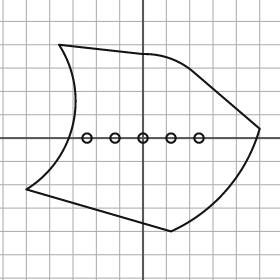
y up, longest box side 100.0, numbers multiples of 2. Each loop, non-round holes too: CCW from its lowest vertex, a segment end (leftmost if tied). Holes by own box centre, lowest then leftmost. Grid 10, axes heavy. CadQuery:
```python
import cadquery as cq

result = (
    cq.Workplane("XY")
    .moveTo(12.0, -40.0)
    .threePointArc((36.0, -22.0), (50.0, 4.0))
    .lineTo(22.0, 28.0)
    .threePointArc((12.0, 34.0), (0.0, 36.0))
    .lineTo(-36.0, 40.0)
    .threePointArc((-30.0, 6.0), (-50.0, -22.0))
    .close()
    .moveTo(-24.0, 0.0)
    .circle(2.0)
    .moveTo(-12.0, 0.0)
    .circle(2.0)
    .moveTo(0.0, 0.0)
    .circle(2.0)
    .moveTo(12.0, 0.0)
    .circle(2.0)
    .moveTo(24.0, 0.0)
    .circle(2.0)
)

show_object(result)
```